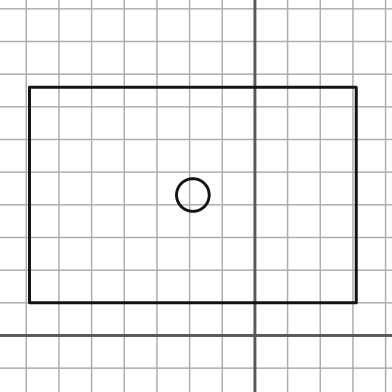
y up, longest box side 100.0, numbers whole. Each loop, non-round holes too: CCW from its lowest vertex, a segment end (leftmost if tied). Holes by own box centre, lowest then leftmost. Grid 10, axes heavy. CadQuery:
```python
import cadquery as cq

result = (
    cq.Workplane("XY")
    .moveTo(-69.0, 10.0)
    .lineTo(31.0, 10.0)
    .lineTo(31.0, 76.0)
    .lineTo(-69.0, 76.0)
    .close()
    .moveTo(-19.0, 43.0)
    .circle(5.0)
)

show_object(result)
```